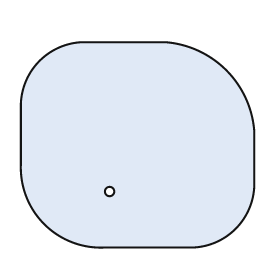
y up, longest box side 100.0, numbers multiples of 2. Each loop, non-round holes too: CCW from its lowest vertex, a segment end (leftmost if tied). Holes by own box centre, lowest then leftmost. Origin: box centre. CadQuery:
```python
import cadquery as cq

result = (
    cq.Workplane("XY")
    .moveTo(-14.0, -44.0)
    .lineTo(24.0, -44.0)
    .threePointArc((42.0, -36.0), (50.0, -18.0))
    .lineTo(50.0, 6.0)
    .threePointArc((38.0, 32.0), (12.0, 44.0))
    .lineTo(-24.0, 44.0)
    .threePointArc((-42.0, 36.0), (-50.0, 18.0))
    .lineTo(-50.0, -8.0)
    .threePointArc((-40.0, -34.0), (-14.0, -44.0))
    .close()
    .moveTo(-12.0, -20.0)
    .circle(2.0)
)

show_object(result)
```